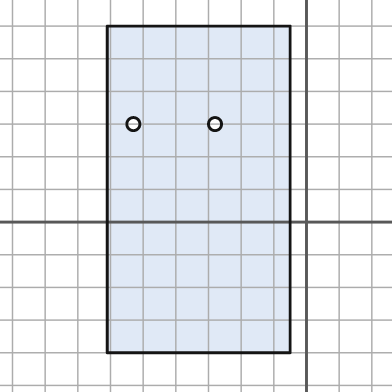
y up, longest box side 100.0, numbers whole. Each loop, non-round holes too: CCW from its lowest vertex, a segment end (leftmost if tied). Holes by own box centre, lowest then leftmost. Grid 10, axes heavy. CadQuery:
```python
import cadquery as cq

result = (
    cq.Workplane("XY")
    .moveTo(-61.0, -40.0)
    .lineTo(-5.0, -40.0)
    .lineTo(-5.0, 60.0)
    .lineTo(-61.0, 60.0)
    .close()
    .moveTo(-53.0, 30.0)
    .circle(2.0)
    .moveTo(-28.0, 30.0)
    .circle(2.0)
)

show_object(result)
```